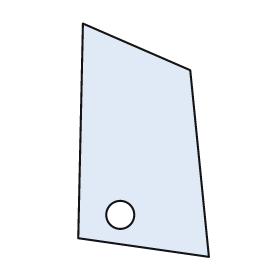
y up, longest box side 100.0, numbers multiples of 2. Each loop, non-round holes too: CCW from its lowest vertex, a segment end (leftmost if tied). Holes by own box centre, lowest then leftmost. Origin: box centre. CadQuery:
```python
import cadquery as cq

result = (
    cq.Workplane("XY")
    .moveTo(28.0, -50.0)
    .lineTo(20.0, 30.0)
    .lineTo(-26.0, 50.0)
    .lineTo(-28.0, -42.0)
    .close()
    .moveTo(-10.0, -32.0)
    .circle(6.0)
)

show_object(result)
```